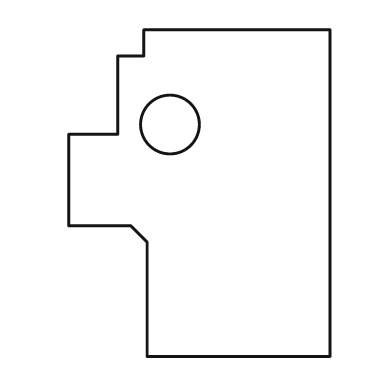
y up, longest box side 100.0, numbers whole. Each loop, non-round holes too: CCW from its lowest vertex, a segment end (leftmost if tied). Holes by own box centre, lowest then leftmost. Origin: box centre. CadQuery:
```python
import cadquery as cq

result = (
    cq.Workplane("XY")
    .moveTo(-16.0, -50.0)
    .lineTo(40.0, -50.0)
    .lineTo(40.0, 50.0)
    .lineTo(-17.0, 50.0)
    .lineTo(-17.0, 42.0)
    .lineTo(-25.0, 42.0)
    .lineTo(-25.0, 18.0)
    .lineTo(-40.0, 18.0)
    .lineTo(-40.0, -10.0)
    .lineTo(-21.0, -10.0)
    .lineTo(-16.0, -15.0)
    .close()
    .moveTo(-9.0, 21.0)
    .circle(9.0)
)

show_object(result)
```